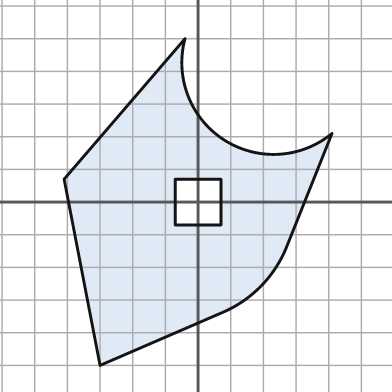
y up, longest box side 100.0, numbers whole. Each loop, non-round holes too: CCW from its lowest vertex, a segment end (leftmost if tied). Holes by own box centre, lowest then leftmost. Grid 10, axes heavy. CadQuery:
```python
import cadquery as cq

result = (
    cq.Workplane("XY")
    .moveTo(-30.0, -50.0)
    .lineTo(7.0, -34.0)
    .threePointArc((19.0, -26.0), (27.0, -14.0))
    .lineTo(41.0, 21.0)
    .threePointArc((8.0, 19.0), (-4.0, 50.0))
    .lineTo(-41.0, 7.0)
    .close()
    .moveTo(-7.0, -7.0)
    .lineTo(7.0, -7.0)
    .lineTo(7.0, 7.0)
    .lineTo(-7.0, 7.0)
    .close()
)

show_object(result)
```